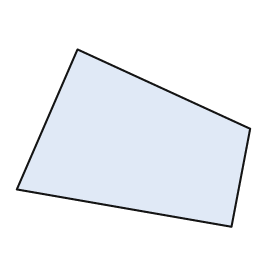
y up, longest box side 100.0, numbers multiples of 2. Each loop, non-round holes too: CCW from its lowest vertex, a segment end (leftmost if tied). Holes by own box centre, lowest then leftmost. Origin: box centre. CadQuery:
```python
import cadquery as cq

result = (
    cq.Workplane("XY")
    .moveTo(42.0, -38.0)
    .lineTo(50.0, 4.0)
    .lineTo(-24.0, 38.0)
    .lineTo(-50.0, -22.0)
    .close()
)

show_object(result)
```